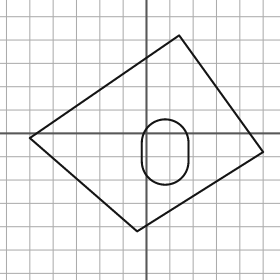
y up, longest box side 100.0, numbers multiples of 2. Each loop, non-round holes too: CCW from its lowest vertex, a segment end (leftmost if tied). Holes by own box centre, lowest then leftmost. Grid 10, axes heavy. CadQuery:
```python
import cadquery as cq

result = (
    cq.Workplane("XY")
    .moveTo(-4.0, -42.0)
    .lineTo(50.0, -8.0)
    .lineTo(14.0, 42.0)
    .lineTo(-50.0, -2.0)
    .close()
    .moveTo(-2.0, -12.0)
    .threePointArc((8.0, -22.0), (18.0, -12.0))
    .lineTo(18.0, -4.0)
    .threePointArc((8.0, 6.0), (-2.0, -4.0))
    .close()
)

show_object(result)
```